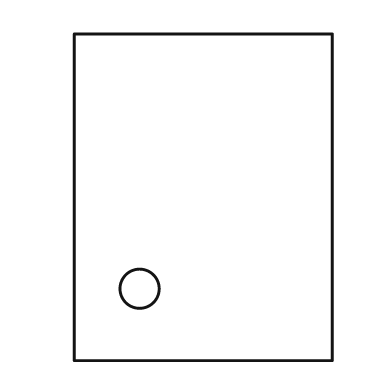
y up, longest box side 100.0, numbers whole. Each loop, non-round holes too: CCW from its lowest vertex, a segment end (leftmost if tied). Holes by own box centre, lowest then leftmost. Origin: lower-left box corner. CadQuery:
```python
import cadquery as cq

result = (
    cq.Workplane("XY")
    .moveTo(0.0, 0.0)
    .lineTo(79.0, 0.0)
    .lineTo(79.0, 100.0)
    .lineTo(0.0, 100.0)
    .close()
    .moveTo(20.0, 22.0)
    .circle(6.0)
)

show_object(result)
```